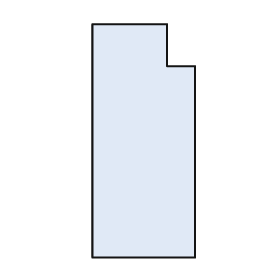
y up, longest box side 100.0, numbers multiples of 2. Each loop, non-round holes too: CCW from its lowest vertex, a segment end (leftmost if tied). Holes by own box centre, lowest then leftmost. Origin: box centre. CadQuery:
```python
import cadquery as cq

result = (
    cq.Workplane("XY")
    .moveTo(-22.0, -50.0)
    .lineTo(22.0, -50.0)
    .lineTo(22.0, 32.0)
    .lineTo(10.0, 32.0)
    .lineTo(10.0, 50.0)
    .lineTo(-22.0, 50.0)
    .close()
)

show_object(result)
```